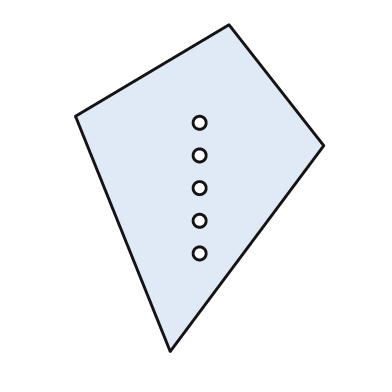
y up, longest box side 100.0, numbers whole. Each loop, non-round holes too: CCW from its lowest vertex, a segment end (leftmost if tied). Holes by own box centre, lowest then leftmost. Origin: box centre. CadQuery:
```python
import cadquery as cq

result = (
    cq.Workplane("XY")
    .moveTo(-9.0, -50.0)
    .lineTo(38.0, 13.0)
    .lineTo(9.0, 50.0)
    .lineTo(-38.0, 22.0)
    .close()
    .moveTo(0.0, -20.0)
    .circle(2.0)
    .moveTo(0.0, -10.0)
    .circle(2.0)
    .moveTo(0.0, 0.0)
    .circle(2.0)
    .moveTo(0.0, 10.0)
    .circle(2.0)
    .moveTo(0.0, 20.0)
    .circle(2.0)
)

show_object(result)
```